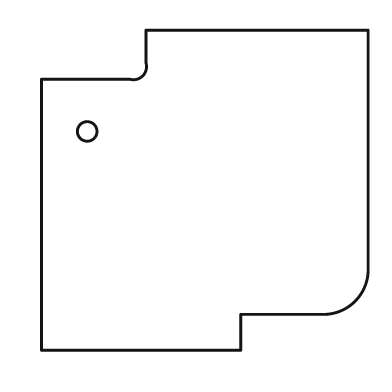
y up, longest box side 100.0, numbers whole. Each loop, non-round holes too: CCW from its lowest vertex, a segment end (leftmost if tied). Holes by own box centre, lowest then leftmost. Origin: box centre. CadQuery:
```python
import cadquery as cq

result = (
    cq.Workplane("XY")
    .moveTo(-50.0, -49.0)
    .lineTo(11.0, -49.0)
    .lineTo(11.0, -38.0)
    .lineTo(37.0, -38.0)
    .threePointArc((46.0, -34.0), (50.0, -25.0))
    .lineTo(50.0, 49.0)
    .lineTo(-18.0, 49.0)
    .lineTo(-18.0, 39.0)
    .threePointArc((-19.0, 35.0), (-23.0, 34.0))
    .lineTo(-50.0, 34.0)
    .close()
    .moveTo(-36.0, 18.0)
    .circle(3.0)
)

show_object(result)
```